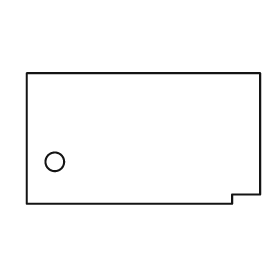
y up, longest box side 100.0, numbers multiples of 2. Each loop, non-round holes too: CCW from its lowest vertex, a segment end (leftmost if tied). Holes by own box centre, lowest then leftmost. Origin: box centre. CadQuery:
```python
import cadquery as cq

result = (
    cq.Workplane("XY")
    .moveTo(-50.0, -28.0)
    .lineTo(38.0, -28.0)
    .lineTo(38.0, -24.0)
    .lineTo(50.0, -24.0)
    .lineTo(50.0, 28.0)
    .lineTo(-50.0, 28.0)
    .close()
    .moveTo(-38.0, -10.0)
    .circle(4.0)
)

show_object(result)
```